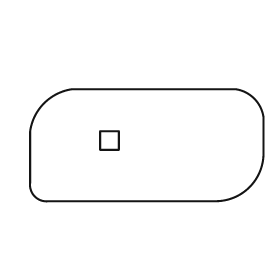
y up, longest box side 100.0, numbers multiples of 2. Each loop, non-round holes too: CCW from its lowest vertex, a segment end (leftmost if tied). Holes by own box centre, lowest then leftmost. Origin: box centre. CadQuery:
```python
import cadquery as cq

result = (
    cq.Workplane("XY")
    .moveTo(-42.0, -24.0)
    .lineTo(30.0, -24.0)
    .threePointArc((44.0, -18.0), (50.0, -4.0))
    .lineTo(50.0, 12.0)
    .threePointArc((46.0, 20.0), (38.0, 24.0))
    .lineTo(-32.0, 24.0)
    .threePointArc((-44.0, 18.0), (-50.0, 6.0))
    .lineTo(-50.0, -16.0)
    .threePointArc((-48.0, -22.0), (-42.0, -24.0))
    .close()
    .moveTo(-20.0, -2.0)
    .lineTo(-12.0, -2.0)
    .lineTo(-12.0, 6.0)
    .lineTo(-20.0, 6.0)
    .close()
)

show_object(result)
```